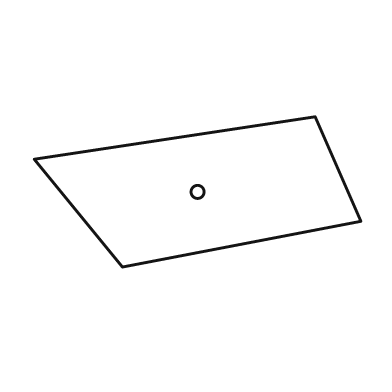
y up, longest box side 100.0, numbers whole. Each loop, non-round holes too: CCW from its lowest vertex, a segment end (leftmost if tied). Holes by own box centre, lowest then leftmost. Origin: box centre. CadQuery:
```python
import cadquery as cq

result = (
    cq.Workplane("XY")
    .moveTo(-23.0, -23.0)
    .lineTo(50.0, -9.0)
    .lineTo(36.0, 23.0)
    .lineTo(-50.0, 10.0)
    .close()
    .moveTo(0.0, 0.0)
    .circle(2.0)
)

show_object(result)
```